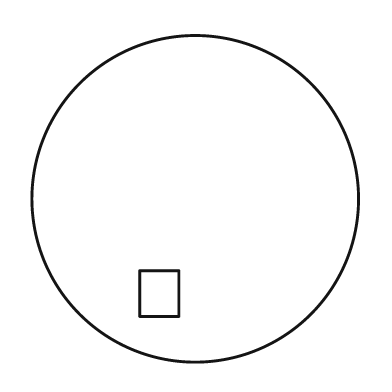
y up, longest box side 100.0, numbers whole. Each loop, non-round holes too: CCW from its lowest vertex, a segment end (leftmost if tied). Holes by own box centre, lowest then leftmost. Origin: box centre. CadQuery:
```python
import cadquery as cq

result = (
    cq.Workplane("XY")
    .moveTo(0.0, 0.0)
    .circle(50.0)
    .moveTo(-17.0, -36.0)
    .lineTo(-5.0, -36.0)
    .lineTo(-5.0, -22.0)
    .lineTo(-17.0, -22.0)
    .close()
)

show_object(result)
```